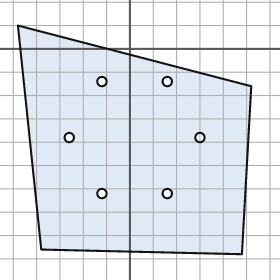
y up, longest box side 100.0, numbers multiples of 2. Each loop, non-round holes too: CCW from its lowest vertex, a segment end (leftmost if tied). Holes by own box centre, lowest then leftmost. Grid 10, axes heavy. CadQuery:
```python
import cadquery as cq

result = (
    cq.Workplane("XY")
    .moveTo(48.0, -88.0)
    .lineTo(52.0, -16.0)
    .lineTo(-48.0, 10.0)
    .lineTo(-38.0, -86.0)
    .close()
    .moveTo(-12.0, -62.0)
    .circle(2.0)
    .moveTo(16.0, -62.0)
    .circle(2.0)
    .moveTo(-26.0, -38.0)
    .circle(2.0)
    .moveTo(30.0, -38.0)
    .circle(2.0)
    .moveTo(-12.0, -14.0)
    .circle(2.0)
    .moveTo(16.0, -14.0)
    .circle(2.0)
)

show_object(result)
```